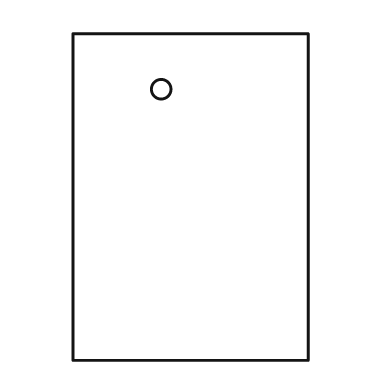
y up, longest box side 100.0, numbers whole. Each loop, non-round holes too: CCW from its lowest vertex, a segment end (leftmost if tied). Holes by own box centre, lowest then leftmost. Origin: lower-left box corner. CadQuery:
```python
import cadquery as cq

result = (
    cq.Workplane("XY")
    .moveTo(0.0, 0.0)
    .lineTo(72.0, 0.0)
    .lineTo(72.0, 100.0)
    .lineTo(0.0, 100.0)
    .close()
    .moveTo(27.0, 83.0)
    .circle(3.0)
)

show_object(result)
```